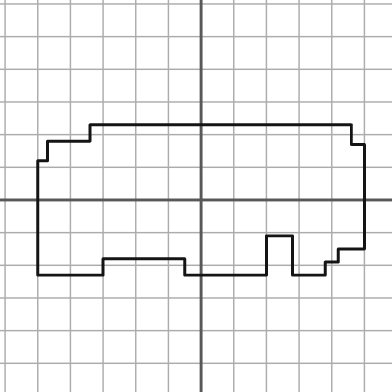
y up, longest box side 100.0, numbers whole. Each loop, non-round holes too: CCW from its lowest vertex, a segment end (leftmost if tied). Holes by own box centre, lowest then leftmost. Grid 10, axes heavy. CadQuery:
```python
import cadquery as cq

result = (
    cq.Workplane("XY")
    .moveTo(-50.0, -23.0)
    .lineTo(-30.0, -23.0)
    .lineTo(-30.0, -18.0)
    .lineTo(-5.0, -18.0)
    .lineTo(-5.0, -23.0)
    .lineTo(20.0, -23.0)
    .lineTo(20.0, -11.0)
    .lineTo(28.0, -11.0)
    .lineTo(28.0, -23.0)
    .lineTo(38.0, -23.0)
    .lineTo(38.0, -19.0)
    .lineTo(42.0, -19.0)
    .lineTo(42.0, -15.0)
    .lineTo(50.0, -15.0)
    .lineTo(50.0, 17.0)
    .lineTo(46.0, 17.0)
    .lineTo(46.0, 23.0)
    .lineTo(-34.0, 23.0)
    .lineTo(-34.0, 18.0)
    .lineTo(-47.0, 18.0)
    .lineTo(-47.0, 12.0)
    .lineTo(-50.0, 12.0)
    .close()
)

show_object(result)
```